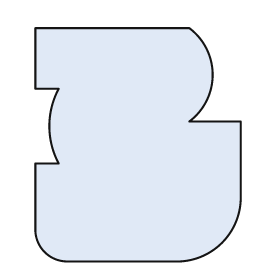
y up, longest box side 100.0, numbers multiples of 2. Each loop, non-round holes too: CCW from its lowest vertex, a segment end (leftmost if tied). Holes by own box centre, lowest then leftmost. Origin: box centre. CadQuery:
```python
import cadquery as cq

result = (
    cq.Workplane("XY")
    .moveTo(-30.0, -50.0)
    .lineTo(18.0, -50.0)
    .threePointArc((36.0, -42.0), (44.0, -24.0))
    .lineTo(44.0, 10.0)
    .lineTo(22.0, 10.0)
    .threePointArc((32.0, 30.0), (22.0, 50.0))
    .lineTo(-44.0, 50.0)
    .lineTo(-44.0, 24.0)
    .lineTo(-34.0, 24.0)
    .threePointArc((-38.0, 8.0), (-34.0, -8.0))
    .lineTo(-44.0, -8.0)
    .lineTo(-44.0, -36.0)
    .threePointArc((-40.0, -46.0), (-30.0, -50.0))
    .close()
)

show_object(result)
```